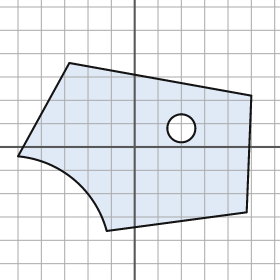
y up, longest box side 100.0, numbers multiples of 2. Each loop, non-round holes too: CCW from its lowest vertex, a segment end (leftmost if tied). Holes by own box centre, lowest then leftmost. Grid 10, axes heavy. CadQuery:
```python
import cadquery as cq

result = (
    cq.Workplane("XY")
    .moveTo(-12.0, -36.0)
    .lineTo(48.0, -28.0)
    .lineTo(50.0, 22.0)
    .lineTo(-28.0, 36.0)
    .lineTo(-50.0, -4.0)
    .threePointArc((-26.0, -14.0), (-12.0, -36.0))
    .close()
    .moveTo(20.0, 8.0)
    .circle(6.0)
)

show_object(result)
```